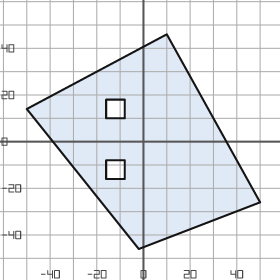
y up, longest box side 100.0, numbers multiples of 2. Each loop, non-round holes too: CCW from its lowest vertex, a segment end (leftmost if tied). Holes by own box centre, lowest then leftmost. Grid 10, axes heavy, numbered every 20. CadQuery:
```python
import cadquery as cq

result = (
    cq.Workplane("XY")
    .moveTo(-2.0, -46.0)
    .lineTo(50.0, -26.0)
    .lineTo(10.0, 46.0)
    .lineTo(-50.0, 14.0)
    .close()
    .moveTo(-16.0, -16.0)
    .lineTo(-8.0, -16.0)
    .lineTo(-8.0, -8.0)
    .lineTo(-16.0, -8.0)
    .close()
    .moveTo(-16.0, 10.0)
    .lineTo(-8.0, 10.0)
    .lineTo(-8.0, 18.0)
    .lineTo(-16.0, 18.0)
    .close()
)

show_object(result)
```